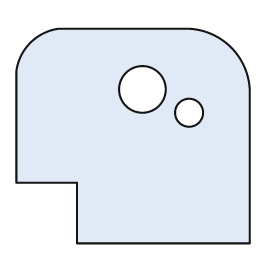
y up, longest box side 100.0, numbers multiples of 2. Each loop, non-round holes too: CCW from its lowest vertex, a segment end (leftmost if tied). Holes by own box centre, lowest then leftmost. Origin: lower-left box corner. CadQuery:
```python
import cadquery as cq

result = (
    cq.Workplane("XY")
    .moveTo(26.0, 0.0)
    .lineTo(100.0, 0.0)
    .lineTo(100.0, 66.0)
    .threePointArc((92.0, 84.0), (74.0, 92.0))
    .lineTo(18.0, 92.0)
    .threePointArc((6.0, 86.0), (0.0, 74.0))
    .lineTo(0.0, 26.0)
    .lineTo(26.0, 26.0)
    .close()
    .moveTo(74.0, 56.0)
    .circle(6.0)
    .moveTo(54.0, 66.0)
    .circle(10.0)
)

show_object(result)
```